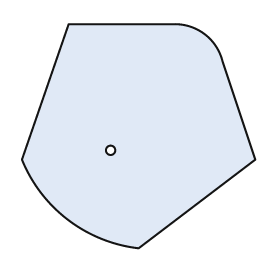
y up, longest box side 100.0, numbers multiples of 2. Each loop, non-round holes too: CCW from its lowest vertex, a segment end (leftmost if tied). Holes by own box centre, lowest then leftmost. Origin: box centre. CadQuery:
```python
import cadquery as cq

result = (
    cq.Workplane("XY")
    .moveTo(0.0, -48.0)
    .lineTo(50.0, -10.0)
    .lineTo(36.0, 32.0)
    .threePointArc((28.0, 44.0), (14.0, 48.0))
    .lineTo(-30.0, 48.0)
    .lineTo(-50.0, -10.0)
    .threePointArc((-30.0, -36.0), (0.0, -48.0))
    .close()
    .moveTo(-12.0, -6.0)
    .circle(2.0)
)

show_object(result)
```